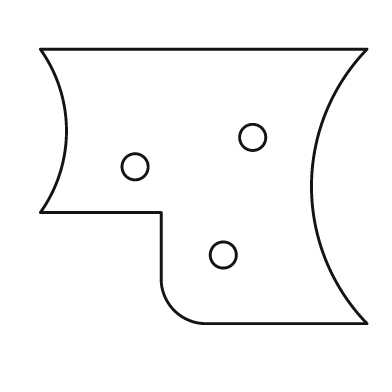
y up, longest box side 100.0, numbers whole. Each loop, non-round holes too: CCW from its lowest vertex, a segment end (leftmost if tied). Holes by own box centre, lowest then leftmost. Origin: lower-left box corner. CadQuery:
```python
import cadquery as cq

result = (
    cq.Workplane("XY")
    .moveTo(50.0, 0.0)
    .lineTo(100.0, 0.0)
    .threePointArc((83.0, 42.0), (100.0, 84.0))
    .lineTo(0.0, 84.0)
    .threePointArc((8.0, 59.0), (0.0, 34.0))
    .lineTo(37.0, 34.0)
    .lineTo(37.0, 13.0)
    .threePointArc((41.0, 4.0), (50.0, 0.0))
    .close()
    .moveTo(56.0, 21.0)
    .circle(4.0)
    .moveTo(29.0, 48.0)
    .circle(4.0)
    .moveTo(65.0, 57.0)
    .circle(4.0)
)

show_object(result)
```